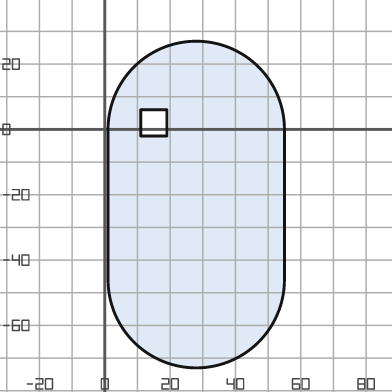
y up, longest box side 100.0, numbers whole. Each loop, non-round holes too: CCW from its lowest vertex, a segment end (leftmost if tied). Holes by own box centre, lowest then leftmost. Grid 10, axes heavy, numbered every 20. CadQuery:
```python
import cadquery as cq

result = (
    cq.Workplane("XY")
    .moveTo(1.0, -46.0)
    .threePointArc((28.0, -73.0), (55.0, -46.0))
    .lineTo(55.0, 0.0)
    .threePointArc((28.0, 27.0), (1.0, 0.0))
    .close()
    .moveTo(11.0, -2.0)
    .lineTo(19.0, -2.0)
    .lineTo(19.0, 6.0)
    .lineTo(11.0, 6.0)
    .close()
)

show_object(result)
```